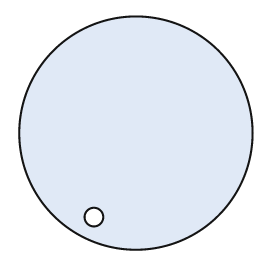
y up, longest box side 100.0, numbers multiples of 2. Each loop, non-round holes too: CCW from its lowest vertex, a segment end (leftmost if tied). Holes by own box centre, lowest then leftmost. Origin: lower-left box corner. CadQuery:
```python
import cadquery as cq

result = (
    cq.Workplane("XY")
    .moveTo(50.0, 50.0)
    .circle(50.0)
    .moveTo(32.0, 14.0)
    .circle(4.0)
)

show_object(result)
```